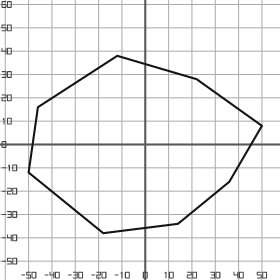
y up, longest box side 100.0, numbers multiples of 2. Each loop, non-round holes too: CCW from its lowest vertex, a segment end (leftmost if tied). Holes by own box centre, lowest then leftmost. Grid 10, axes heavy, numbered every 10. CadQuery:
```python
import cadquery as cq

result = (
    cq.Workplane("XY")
    .moveTo(-18.0, -38.0)
    .lineTo(14.0, -34.0)
    .lineTo(36.0, -16.0)
    .lineTo(50.0, 8.0)
    .lineTo(22.0, 28.0)
    .lineTo(-12.0, 38.0)
    .lineTo(-46.0, 16.0)
    .lineTo(-50.0, -12.0)
    .close()
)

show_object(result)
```